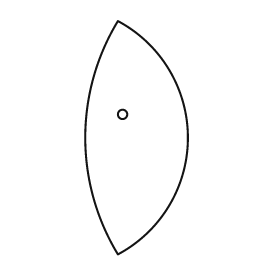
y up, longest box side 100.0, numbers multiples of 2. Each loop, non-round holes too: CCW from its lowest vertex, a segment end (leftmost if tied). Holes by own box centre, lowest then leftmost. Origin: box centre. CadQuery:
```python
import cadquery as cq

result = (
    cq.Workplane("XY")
    .moveTo(-8.0, -50.0)
    .threePointArc((22.0, 0.0), (-8.0, 50.0))
    .threePointArc((-22.0, 0.0), (-8.0, -50.0))
    .close()
    .moveTo(-6.0, 10.0)
    .circle(2.0)
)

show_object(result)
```